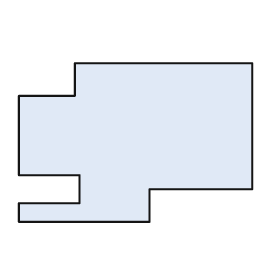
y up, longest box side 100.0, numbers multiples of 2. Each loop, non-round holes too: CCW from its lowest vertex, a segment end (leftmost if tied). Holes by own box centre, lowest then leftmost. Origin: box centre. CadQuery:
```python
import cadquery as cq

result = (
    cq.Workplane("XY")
    .moveTo(-50.0, -34.0)
    .lineTo(6.0, -34.0)
    .lineTo(6.0, -20.0)
    .lineTo(50.0, -20.0)
    .lineTo(50.0, 34.0)
    .lineTo(-26.0, 34.0)
    .lineTo(-26.0, 20.0)
    .lineTo(-50.0, 20.0)
    .lineTo(-50.0, -14.0)
    .lineTo(-24.0, -14.0)
    .lineTo(-24.0, -26.0)
    .lineTo(-50.0, -26.0)
    .close()
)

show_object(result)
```